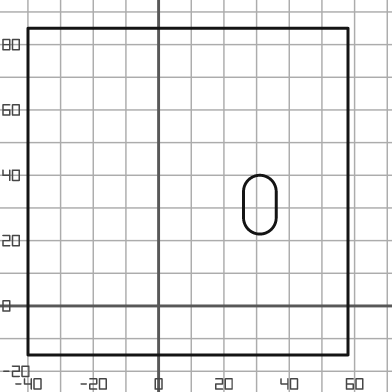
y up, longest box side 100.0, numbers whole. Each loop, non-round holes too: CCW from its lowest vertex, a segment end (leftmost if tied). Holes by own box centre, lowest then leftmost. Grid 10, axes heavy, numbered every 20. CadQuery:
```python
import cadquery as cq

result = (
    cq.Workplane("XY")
    .moveTo(-40.0, -15.0)
    .lineTo(58.0, -15.0)
    .lineTo(58.0, 85.0)
    .lineTo(-40.0, 85.0)
    .close()
    .moveTo(26.0, 27.0)
    .threePointArc((31.0, 22.0), (36.0, 27.0))
    .lineTo(36.0, 35.0)
    .threePointArc((31.0, 40.0), (26.0, 35.0))
    .close()
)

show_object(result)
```